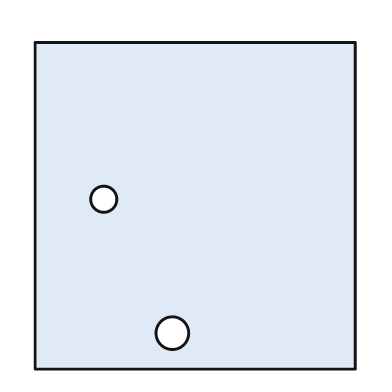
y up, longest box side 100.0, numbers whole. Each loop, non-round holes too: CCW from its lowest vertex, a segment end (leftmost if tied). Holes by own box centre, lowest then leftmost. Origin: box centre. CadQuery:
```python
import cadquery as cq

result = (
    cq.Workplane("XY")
    .moveTo(-49.0, -50.0)
    .lineTo(49.0, -50.0)
    .lineTo(49.0, 50.0)
    .lineTo(-49.0, 50.0)
    .close()
    .moveTo(-7.0, -39.0)
    .circle(5.0)
    .moveTo(-28.0, 2.0)
    .circle(4.0)
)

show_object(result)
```